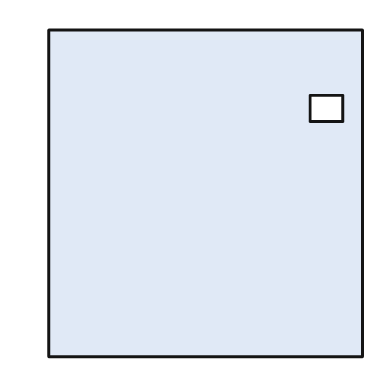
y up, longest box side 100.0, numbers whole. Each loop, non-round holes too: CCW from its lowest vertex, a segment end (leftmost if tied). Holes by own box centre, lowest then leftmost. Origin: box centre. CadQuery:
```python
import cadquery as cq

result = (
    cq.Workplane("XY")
    .moveTo(-48.0, -50.0)
    .lineTo(48.0, -50.0)
    .lineTo(48.0, 50.0)
    .lineTo(-48.0, 50.0)
    .close()
    .moveTo(32.0, 22.0)
    .lineTo(42.0, 22.0)
    .lineTo(42.0, 30.0)
    .lineTo(32.0, 30.0)
    .close()
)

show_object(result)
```